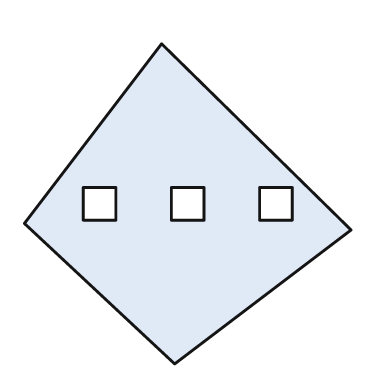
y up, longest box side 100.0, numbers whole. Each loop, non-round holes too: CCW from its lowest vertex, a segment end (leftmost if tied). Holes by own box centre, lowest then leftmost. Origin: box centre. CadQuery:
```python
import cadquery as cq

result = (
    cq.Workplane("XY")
    .moveTo(-4.0, -49.0)
    .lineTo(50.0, -8.0)
    .lineTo(-8.0, 49.0)
    .lineTo(-50.0, -6.0)
    .close()
    .moveTo(-32.0, -5.0)
    .lineTo(-22.0, -5.0)
    .lineTo(-22.0, 5.0)
    .lineTo(-32.0, 5.0)
    .close()
    .moveTo(-5.0, -5.0)
    .lineTo(5.0, -5.0)
    .lineTo(5.0, 5.0)
    .lineTo(-5.0, 5.0)
    .close()
    .moveTo(22.0, -5.0)
    .lineTo(32.0, -5.0)
    .lineTo(32.0, 5.0)
    .lineTo(22.0, 5.0)
    .close()
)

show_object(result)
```